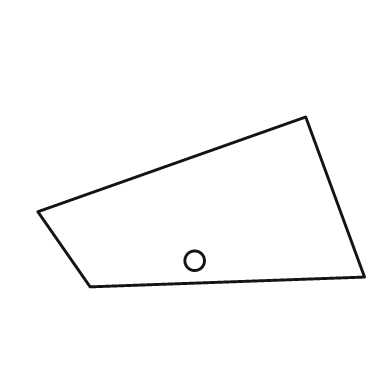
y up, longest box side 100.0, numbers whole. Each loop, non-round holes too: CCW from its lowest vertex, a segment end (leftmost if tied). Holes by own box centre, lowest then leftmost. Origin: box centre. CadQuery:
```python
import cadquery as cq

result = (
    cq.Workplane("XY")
    .moveTo(-34.0, -26.0)
    .lineTo(50.0, -23.0)
    .lineTo(32.0, 26.0)
    .lineTo(-50.0, -3.0)
    .close()
    .moveTo(-2.0, -18.0)
    .circle(3.0)
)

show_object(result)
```